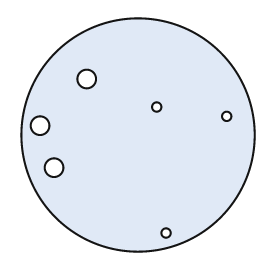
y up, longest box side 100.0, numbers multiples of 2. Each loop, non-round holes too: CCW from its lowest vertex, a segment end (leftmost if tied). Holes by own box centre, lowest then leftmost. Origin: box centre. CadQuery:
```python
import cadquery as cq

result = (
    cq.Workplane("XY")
    .moveTo(0.0, 0.0)
    .circle(50.0)
    .moveTo(12.0, -42.0)
    .circle(2.0)
    .moveTo(-36.0, -14.0)
    .circle(4.0)
    .moveTo(-42.0, 4.0)
    .circle(4.0)
    .moveTo(38.0, 8.0)
    .circle(2.0)
    .moveTo(8.0, 12.0)
    .circle(2.0)
    .moveTo(-22.0, 24.0)
    .circle(4.0)
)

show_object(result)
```